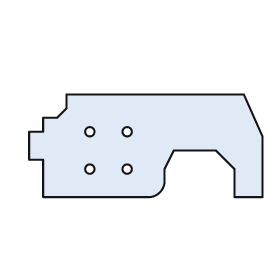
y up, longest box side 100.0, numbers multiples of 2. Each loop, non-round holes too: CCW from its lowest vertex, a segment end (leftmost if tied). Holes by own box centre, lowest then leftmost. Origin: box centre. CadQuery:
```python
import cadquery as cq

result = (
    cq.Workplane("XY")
    .moveTo(-44.0, -22.0)
    .lineTo(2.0, -22.0)
    .threePointArc((6.0, -20.0), (8.0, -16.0))
    .lineTo(8.0, -10.0)
    .lineTo(12.0, -2.0)
    .lineTo(30.0, -2.0)
    .lineTo(38.0, -10.0)
    .lineTo(38.0, -22.0)
    .lineTo(50.0, -22.0)
    .lineTo(50.0, 4.0)
    .lineTo(42.0, 22.0)
    .lineTo(-34.0, 22.0)
    .lineTo(-34.0, 16.0)
    .lineTo(-38.0, 12.0)
    .lineTo(-44.0, 12.0)
    .lineTo(-44.0, 6.0)
    .lineTo(-50.0, 6.0)
    .lineTo(-50.0, -6.0)
    .lineTo(-44.0, -6.0)
    .close()
    .moveTo(-24.0, -10.0)
    .circle(2.0)
    .moveTo(-8.0, -10.0)
    .circle(2.0)
    .moveTo(-24.0, 6.0)
    .circle(2.0)
    .moveTo(-8.0, 6.0)
    .circle(2.0)
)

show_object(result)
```